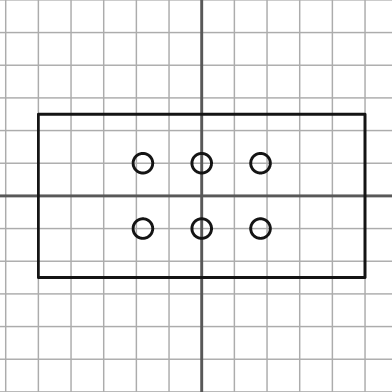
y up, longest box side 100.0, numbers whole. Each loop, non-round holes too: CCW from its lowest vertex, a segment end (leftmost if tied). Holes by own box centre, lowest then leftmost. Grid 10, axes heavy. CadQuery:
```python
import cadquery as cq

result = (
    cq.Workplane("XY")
    .moveTo(-50.0, -25.0)
    .lineTo(50.0, -25.0)
    .lineTo(50.0, 25.0)
    .lineTo(-50.0, 25.0)
    .close()
    .moveTo(-18.0, -10.0)
    .circle(3.0)
    .moveTo(0.0, -10.0)
    .circle(3.0)
    .moveTo(18.0, -10.0)
    .circle(3.0)
    .moveTo(-18.0, 10.0)
    .circle(3.0)
    .moveTo(0.0, 10.0)
    .circle(3.0)
    .moveTo(18.0, 10.0)
    .circle(3.0)
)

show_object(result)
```